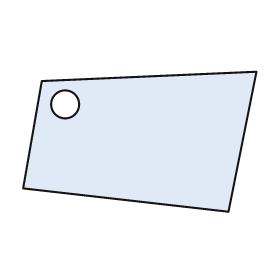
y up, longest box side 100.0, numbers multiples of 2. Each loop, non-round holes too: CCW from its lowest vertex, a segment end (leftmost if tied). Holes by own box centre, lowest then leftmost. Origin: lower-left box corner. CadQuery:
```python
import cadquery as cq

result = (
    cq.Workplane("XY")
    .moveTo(88.0, 0.0)
    .lineTo(100.0, 60.0)
    .lineTo(8.0, 56.0)
    .lineTo(0.0, 10.0)
    .close()
    .moveTo(18.0, 46.0)
    .circle(6.0)
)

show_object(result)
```